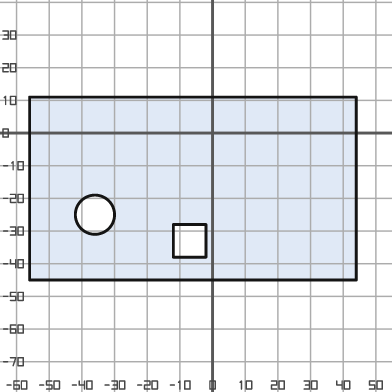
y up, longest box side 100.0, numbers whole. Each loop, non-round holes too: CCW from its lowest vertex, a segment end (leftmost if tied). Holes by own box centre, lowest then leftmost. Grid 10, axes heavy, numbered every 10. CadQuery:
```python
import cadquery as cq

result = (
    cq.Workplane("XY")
    .moveTo(-56.0, -45.0)
    .lineTo(44.0, -45.0)
    .lineTo(44.0, 11.0)
    .lineTo(-56.0, 11.0)
    .close()
    .moveTo(-12.0, -38.0)
    .lineTo(-2.0, -38.0)
    .lineTo(-2.0, -28.0)
    .lineTo(-12.0, -28.0)
    .close()
    .moveTo(-36.0, -25.0)
    .circle(6.0)
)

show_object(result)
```